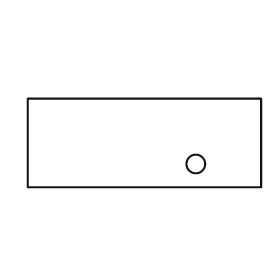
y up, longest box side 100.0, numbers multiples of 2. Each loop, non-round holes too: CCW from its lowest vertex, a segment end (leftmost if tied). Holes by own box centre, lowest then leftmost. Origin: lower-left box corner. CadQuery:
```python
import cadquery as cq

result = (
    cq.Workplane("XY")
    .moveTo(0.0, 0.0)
    .lineTo(100.0, 0.0)
    .lineTo(100.0, 38.0)
    .lineTo(0.0, 38.0)
    .close()
    .moveTo(72.0, 10.0)
    .circle(4.0)
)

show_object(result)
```